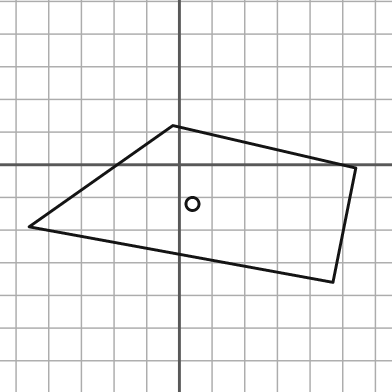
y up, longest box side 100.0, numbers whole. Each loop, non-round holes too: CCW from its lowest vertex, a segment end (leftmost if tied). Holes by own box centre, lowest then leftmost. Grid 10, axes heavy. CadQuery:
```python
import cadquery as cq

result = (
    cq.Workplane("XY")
    .moveTo(47.0, -36.0)
    .lineTo(54.0, -1.0)
    .lineTo(-2.0, 12.0)
    .lineTo(-46.0, -19.0)
    .close()
    .moveTo(4.0, -12.0)
    .circle(2.0)
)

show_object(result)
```